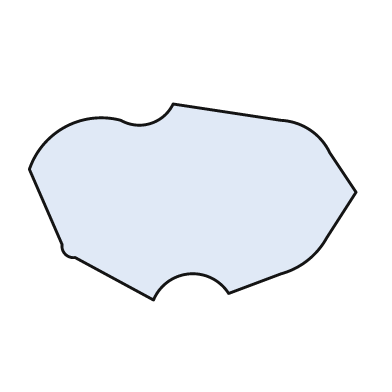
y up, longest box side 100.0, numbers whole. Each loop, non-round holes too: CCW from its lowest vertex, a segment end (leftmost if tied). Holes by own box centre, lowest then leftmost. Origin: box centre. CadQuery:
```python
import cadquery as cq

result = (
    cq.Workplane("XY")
    .moveTo(-12.0, -30.0)
    .threePointArc((-1.0, -22.0), (11.0, -28.0))
    .lineTo(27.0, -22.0)
    .threePointArc((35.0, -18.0), (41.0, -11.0))
    .lineTo(50.0, 3.0)
    .lineTo(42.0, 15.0)
    .threePointArc((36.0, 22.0), (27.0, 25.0))
    .lineTo(-6.0, 30.0)
    .threePointArc((-13.0, 24.0), (-22.0, 25.0))
    .threePointArc((-39.0, 23.0), (-50.0, 10.0))
    .lineTo(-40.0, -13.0)
    .threePointArc((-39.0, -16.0), (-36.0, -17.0))
    .close()
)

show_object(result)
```